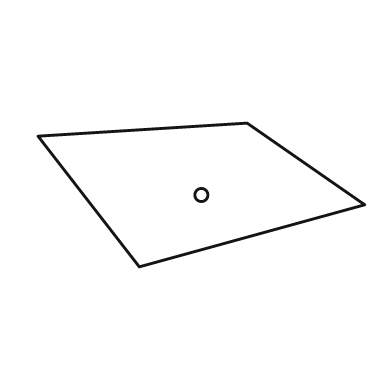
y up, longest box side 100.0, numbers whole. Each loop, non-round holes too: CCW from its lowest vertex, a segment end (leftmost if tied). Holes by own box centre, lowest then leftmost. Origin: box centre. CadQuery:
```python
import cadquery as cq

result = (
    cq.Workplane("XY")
    .moveTo(-19.0, -22.0)
    .lineTo(50.0, -3.0)
    .lineTo(14.0, 22.0)
    .lineTo(-50.0, 18.0)
    .close()
    .moveTo(0.0, 0.0)
    .circle(2.0)
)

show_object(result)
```